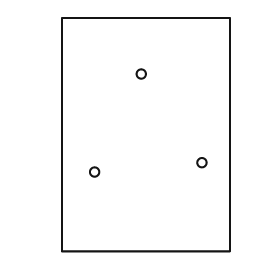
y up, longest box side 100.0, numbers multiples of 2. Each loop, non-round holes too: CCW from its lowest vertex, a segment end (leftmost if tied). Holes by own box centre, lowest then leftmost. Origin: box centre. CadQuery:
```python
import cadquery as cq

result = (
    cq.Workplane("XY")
    .moveTo(-36.0, -50.0)
    .lineTo(36.0, -50.0)
    .lineTo(36.0, 50.0)
    .lineTo(-36.0, 50.0)
    .close()
    .moveTo(-22.0, -16.0)
    .circle(2.0)
    .moveTo(24.0, -12.0)
    .circle(2.0)
    .moveTo(-2.0, 26.0)
    .circle(2.0)
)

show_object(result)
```